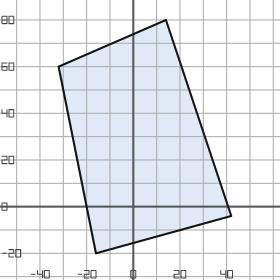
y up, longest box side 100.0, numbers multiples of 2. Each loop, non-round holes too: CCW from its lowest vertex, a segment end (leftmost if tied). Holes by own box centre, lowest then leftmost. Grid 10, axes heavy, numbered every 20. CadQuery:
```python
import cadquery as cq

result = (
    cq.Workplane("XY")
    .moveTo(-16.0, -20.0)
    .lineTo(42.0, -4.0)
    .lineTo(14.0, 80.0)
    .lineTo(-32.0, 60.0)
    .close()
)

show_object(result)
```